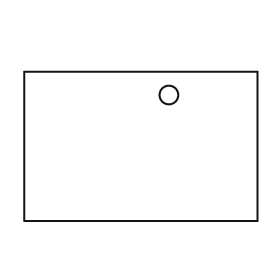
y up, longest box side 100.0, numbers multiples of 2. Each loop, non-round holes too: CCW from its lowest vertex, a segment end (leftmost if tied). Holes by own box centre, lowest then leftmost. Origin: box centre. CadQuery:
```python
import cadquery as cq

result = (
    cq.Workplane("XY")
    .moveTo(-50.0, -32.0)
    .lineTo(50.0, -32.0)
    .lineTo(50.0, 32.0)
    .lineTo(-50.0, 32.0)
    .close()
    .moveTo(12.0, 22.0)
    .circle(4.0)
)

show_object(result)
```